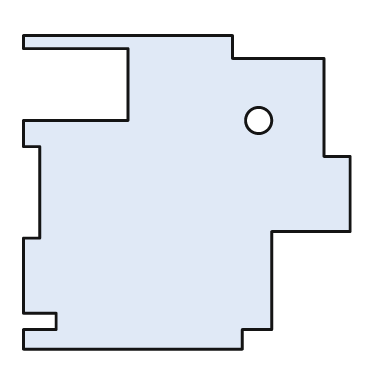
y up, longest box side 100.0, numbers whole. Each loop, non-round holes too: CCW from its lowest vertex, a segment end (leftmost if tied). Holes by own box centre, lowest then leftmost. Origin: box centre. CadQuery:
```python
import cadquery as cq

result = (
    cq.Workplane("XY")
    .moveTo(-50.0, -48.0)
    .lineTo(17.0, -48.0)
    .lineTo(17.0, -42.0)
    .lineTo(26.0, -42.0)
    .lineTo(26.0, -12.0)
    .lineTo(50.0, -12.0)
    .lineTo(50.0, 11.0)
    .lineTo(42.0, 11.0)
    .lineTo(42.0, 41.0)
    .lineTo(14.0, 41.0)
    .lineTo(14.0, 48.0)
    .lineTo(-50.0, 48.0)
    .lineTo(-50.0, 44.0)
    .lineTo(-18.0, 44.0)
    .lineTo(-18.0, 22.0)
    .lineTo(-50.0, 22.0)
    .lineTo(-50.0, 14.0)
    .lineTo(-45.0, 14.0)
    .lineTo(-45.0, -14.0)
    .lineTo(-50.0, -14.0)
    .lineTo(-50.0, -37.0)
    .lineTo(-40.0, -37.0)
    .lineTo(-40.0, -42.0)
    .lineTo(-50.0, -42.0)
    .close()
    .moveTo(22.0, 22.0)
    .circle(4.0)
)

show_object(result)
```